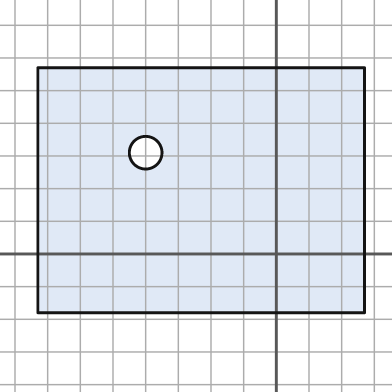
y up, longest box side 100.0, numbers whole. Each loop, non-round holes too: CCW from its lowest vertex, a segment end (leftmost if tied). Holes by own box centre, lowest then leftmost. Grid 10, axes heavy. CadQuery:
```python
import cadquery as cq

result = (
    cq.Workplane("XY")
    .moveTo(-73.0, -18.0)
    .lineTo(27.0, -18.0)
    .lineTo(27.0, 57.0)
    .lineTo(-73.0, 57.0)
    .close()
    .moveTo(-40.0, 31.0)
    .circle(5.0)
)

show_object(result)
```